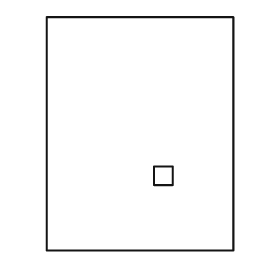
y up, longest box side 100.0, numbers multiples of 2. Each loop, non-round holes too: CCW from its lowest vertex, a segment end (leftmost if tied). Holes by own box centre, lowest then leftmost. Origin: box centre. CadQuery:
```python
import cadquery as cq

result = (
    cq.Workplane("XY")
    .moveTo(-40.0, -50.0)
    .lineTo(40.0, -50.0)
    .lineTo(40.0, 50.0)
    .lineTo(-40.0, 50.0)
    .close()
    .moveTo(6.0, -22.0)
    .lineTo(14.0, -22.0)
    .lineTo(14.0, -14.0)
    .lineTo(6.0, -14.0)
    .close()
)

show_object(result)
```